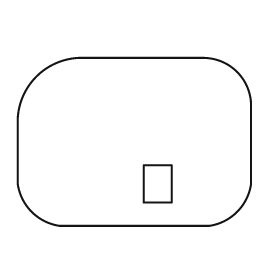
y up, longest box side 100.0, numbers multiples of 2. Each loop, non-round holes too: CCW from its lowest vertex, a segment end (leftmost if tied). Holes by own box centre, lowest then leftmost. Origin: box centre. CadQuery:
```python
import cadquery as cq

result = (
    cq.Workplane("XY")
    .moveTo(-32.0, -36.0)
    .lineTo(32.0, -36.0)
    .threePointArc((44.0, -30.0), (50.0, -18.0))
    .lineTo(50.0, 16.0)
    .threePointArc((44.0, 30.0), (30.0, 36.0))
    .lineTo(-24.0, 36.0)
    .threePointArc((-42.0, 28.0), (-50.0, 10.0))
    .lineTo(-50.0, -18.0)
    .threePointArc((-44.0, -30.0), (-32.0, -36.0))
    .close()
    .moveTo(4.0, -26.0)
    .lineTo(16.0, -26.0)
    .lineTo(16.0, -10.0)
    .lineTo(4.0, -10.0)
    .close()
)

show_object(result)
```